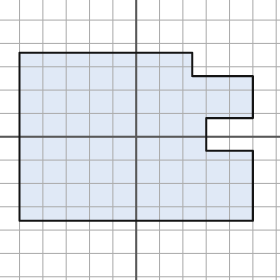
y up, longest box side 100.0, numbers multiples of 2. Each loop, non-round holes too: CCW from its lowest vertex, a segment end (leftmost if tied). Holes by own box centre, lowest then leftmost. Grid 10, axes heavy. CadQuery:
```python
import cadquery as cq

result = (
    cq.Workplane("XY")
    .moveTo(-50.0, -36.0)
    .lineTo(50.0, -36.0)
    .lineTo(50.0, -6.0)
    .lineTo(30.0, -6.0)
    .lineTo(30.0, 8.0)
    .lineTo(50.0, 8.0)
    .lineTo(50.0, 26.0)
    .lineTo(24.0, 26.0)
    .lineTo(24.0, 36.0)
    .lineTo(-50.0, 36.0)
    .close()
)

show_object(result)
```